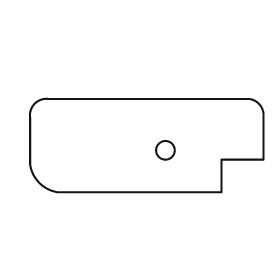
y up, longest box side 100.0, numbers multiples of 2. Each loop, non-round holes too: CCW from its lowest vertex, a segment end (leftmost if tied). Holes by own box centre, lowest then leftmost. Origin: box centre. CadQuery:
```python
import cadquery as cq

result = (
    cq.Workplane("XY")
    .moveTo(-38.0, -20.0)
    .lineTo(32.0, -20.0)
    .lineTo(32.0, -6.0)
    .lineTo(50.0, -6.0)
    .lineTo(50.0, 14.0)
    .threePointArc((48.0, 18.0), (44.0, 20.0))
    .lineTo(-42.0, 20.0)
    .threePointArc((-48.0, 18.0), (-50.0, 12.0))
    .lineTo(-50.0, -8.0)
    .threePointArc((-46.0, -16.0), (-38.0, -20.0))
    .close()
    .moveTo(8.0, -2.0)
    .circle(4.0)
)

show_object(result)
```